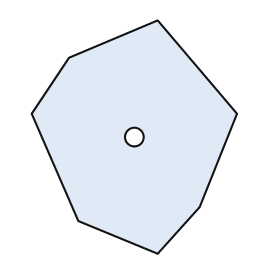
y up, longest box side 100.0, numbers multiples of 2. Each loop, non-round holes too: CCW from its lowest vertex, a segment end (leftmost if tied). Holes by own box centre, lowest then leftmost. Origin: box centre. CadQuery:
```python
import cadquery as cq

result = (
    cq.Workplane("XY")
    .moveTo(10.0, -50.0)
    .lineTo(28.0, -30.0)
    .lineTo(44.0, 10.0)
    .lineTo(10.0, 50.0)
    .lineTo(-28.0, 34.0)
    .lineTo(-44.0, 10.0)
    .lineTo(-24.0, -36.0)
    .close()
    .moveTo(0.0, 0.0)
    .circle(4.0)
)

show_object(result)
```